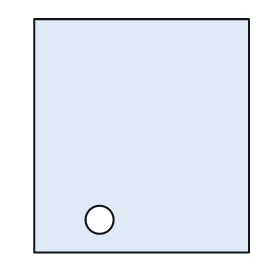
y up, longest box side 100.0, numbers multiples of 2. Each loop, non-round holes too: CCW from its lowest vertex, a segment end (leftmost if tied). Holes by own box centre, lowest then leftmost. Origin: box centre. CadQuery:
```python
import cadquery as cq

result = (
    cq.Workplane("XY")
    .moveTo(-46.0, -50.0)
    .lineTo(46.0, -50.0)
    .lineTo(46.0, 50.0)
    .lineTo(-46.0, 50.0)
    .close()
    .moveTo(-18.0, -36.0)
    .circle(6.0)
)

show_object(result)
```